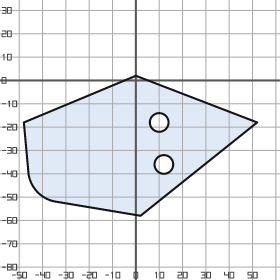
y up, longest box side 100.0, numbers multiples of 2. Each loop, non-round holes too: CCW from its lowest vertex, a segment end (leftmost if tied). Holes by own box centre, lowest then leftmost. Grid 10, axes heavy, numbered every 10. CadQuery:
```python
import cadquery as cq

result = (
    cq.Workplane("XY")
    .moveTo(2.0, -58.0)
    .lineTo(52.0, -18.0)
    .lineTo(0.0, 2.0)
    .lineTo(-48.0, -18.0)
    .lineTo(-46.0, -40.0)
    .threePointArc((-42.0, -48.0), (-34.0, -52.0))
    .close()
    .moveTo(12.0, -36.0)
    .circle(4.0)
    .moveTo(10.0, -18.0)
    .circle(4.0)
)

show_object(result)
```